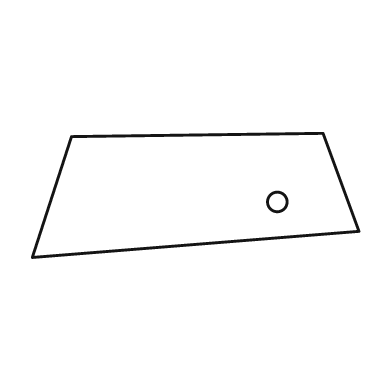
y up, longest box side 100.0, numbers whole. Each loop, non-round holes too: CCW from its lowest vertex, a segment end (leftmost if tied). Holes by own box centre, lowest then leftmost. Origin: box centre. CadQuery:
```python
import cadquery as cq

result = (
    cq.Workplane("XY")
    .moveTo(-50.0, -19.0)
    .lineTo(50.0, -11.0)
    .lineTo(39.0, 19.0)
    .lineTo(-38.0, 18.0)
    .close()
    .moveTo(25.0, -2.0)
    .circle(3.0)
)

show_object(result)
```